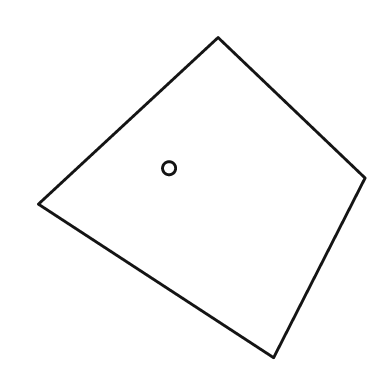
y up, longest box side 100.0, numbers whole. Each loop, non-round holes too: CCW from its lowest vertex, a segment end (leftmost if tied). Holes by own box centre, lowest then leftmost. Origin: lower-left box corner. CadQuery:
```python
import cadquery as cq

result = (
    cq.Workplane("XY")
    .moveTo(72.0, 0.0)
    .lineTo(100.0, 55.0)
    .lineTo(55.0, 98.0)
    .lineTo(0.0, 47.0)
    .close()
    .moveTo(40.0, 58.0)
    .circle(2.0)
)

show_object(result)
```